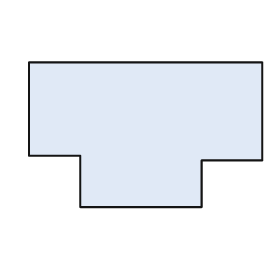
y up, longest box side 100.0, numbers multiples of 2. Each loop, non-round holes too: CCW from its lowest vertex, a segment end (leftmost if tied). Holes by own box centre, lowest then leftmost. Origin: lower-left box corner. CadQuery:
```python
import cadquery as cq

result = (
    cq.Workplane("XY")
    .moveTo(22.0, 0.0)
    .lineTo(74.0, 0.0)
    .lineTo(74.0, 20.0)
    .lineTo(100.0, 20.0)
    .lineTo(100.0, 62.0)
    .lineTo(0.0, 62.0)
    .lineTo(0.0, 22.0)
    .lineTo(22.0, 22.0)
    .close()
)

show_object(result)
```